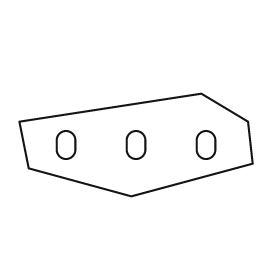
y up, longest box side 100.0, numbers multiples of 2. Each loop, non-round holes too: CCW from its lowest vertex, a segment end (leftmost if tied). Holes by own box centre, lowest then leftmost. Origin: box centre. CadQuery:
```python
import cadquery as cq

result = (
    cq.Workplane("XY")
    .moveTo(-2.0, -22.0)
    .lineTo(50.0, -8.0)
    .lineTo(48.0, 10.0)
    .lineTo(28.0, 22.0)
    .lineTo(-50.0, 10.0)
    .lineTo(-46.0, -10.0)
    .close()
    .moveTo(-34.0, -2.0)
    .threePointArc((-30.0, -6.0), (-26.0, -2.0))
    .lineTo(-26.0, 2.0)
    .threePointArc((-30.0, 6.0), (-34.0, 2.0))
    .close()
    .moveTo(-4.0, -2.0)
    .threePointArc((0.0, -6.0), (4.0, -2.0))
    .lineTo(4.0, 2.0)
    .threePointArc((0.0, 6.0), (-4.0, 2.0))
    .close()
    .moveTo(26.0, -2.0)
    .threePointArc((30.0, -6.0), (34.0, -2.0))
    .lineTo(34.0, 2.0)
    .threePointArc((30.0, 6.0), (26.0, 2.0))
    .close()
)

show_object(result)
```